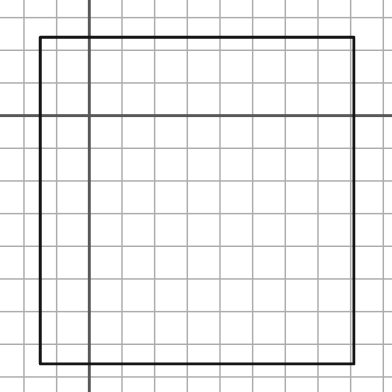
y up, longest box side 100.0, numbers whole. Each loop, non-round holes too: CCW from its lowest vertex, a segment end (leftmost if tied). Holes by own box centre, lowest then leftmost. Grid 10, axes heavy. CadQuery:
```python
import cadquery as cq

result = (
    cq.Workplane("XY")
    .moveTo(-15.0, -76.0)
    .lineTo(81.0, -76.0)
    .lineTo(81.0, 24.0)
    .lineTo(-15.0, 24.0)
    .close()
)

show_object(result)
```